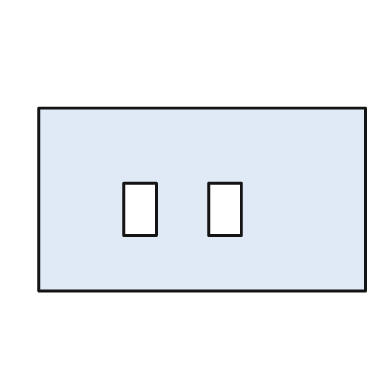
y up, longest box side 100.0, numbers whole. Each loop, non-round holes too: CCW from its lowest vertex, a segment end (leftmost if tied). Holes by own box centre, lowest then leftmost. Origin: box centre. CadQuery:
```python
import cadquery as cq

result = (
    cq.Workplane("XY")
    .moveTo(-50.0, -28.0)
    .lineTo(50.0, -28.0)
    .lineTo(50.0, 28.0)
    .lineTo(-50.0, 28.0)
    .close()
    .moveTo(-24.0, -11.0)
    .lineTo(-14.0, -11.0)
    .lineTo(-14.0, 5.0)
    .lineTo(-24.0, 5.0)
    .close()
    .moveTo(2.0, -11.0)
    .lineTo(12.0, -11.0)
    .lineTo(12.0, 5.0)
    .lineTo(2.0, 5.0)
    .close()
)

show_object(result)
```